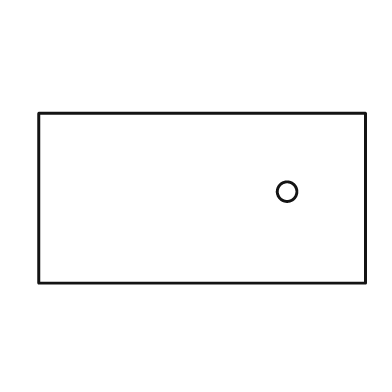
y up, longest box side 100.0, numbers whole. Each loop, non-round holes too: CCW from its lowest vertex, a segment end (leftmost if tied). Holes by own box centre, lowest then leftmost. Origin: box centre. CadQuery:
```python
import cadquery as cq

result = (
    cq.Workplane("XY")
    .moveTo(-50.0, -26.0)
    .lineTo(50.0, -26.0)
    .lineTo(50.0, 26.0)
    .lineTo(-50.0, 26.0)
    .close()
    .moveTo(26.0, 2.0)
    .circle(3.0)
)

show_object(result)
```